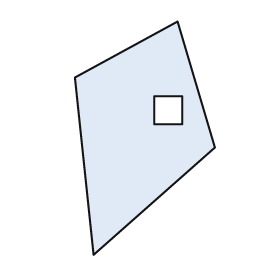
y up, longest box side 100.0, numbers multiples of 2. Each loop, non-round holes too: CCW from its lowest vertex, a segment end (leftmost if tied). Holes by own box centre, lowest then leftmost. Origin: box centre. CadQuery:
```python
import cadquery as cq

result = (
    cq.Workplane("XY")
    .moveTo(-22.0, -50.0)
    .lineTo(30.0, -4.0)
    .lineTo(14.0, 50.0)
    .lineTo(-30.0, 26.0)
    .close()
    .moveTo(4.0, 6.0)
    .lineTo(16.0, 6.0)
    .lineTo(16.0, 18.0)
    .lineTo(4.0, 18.0)
    .close()
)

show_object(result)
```